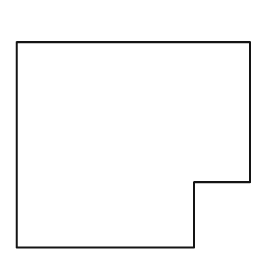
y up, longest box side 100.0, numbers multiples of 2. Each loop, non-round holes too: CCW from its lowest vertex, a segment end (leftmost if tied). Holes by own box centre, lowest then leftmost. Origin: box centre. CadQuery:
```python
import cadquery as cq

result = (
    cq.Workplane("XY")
    .moveTo(-50.0, -44.0)
    .lineTo(26.0, -44.0)
    .lineTo(26.0, -16.0)
    .lineTo(50.0, -16.0)
    .lineTo(50.0, 44.0)
    .lineTo(-50.0, 44.0)
    .close()
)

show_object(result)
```